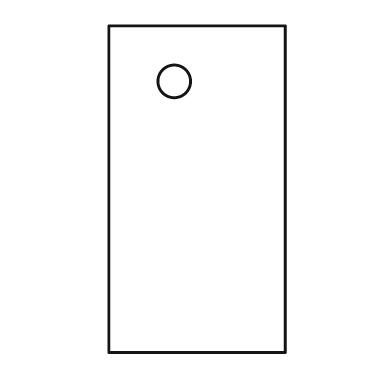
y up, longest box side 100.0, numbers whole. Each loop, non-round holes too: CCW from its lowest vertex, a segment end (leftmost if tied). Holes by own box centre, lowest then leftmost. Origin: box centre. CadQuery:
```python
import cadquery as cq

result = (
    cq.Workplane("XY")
    .moveTo(-27.0, -50.0)
    .lineTo(27.0, -50.0)
    .lineTo(27.0, 50.0)
    .lineTo(-27.0, 50.0)
    .close()
    .moveTo(-7.0, 33.0)
    .circle(5.0)
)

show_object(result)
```